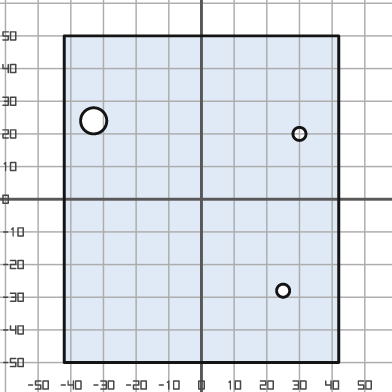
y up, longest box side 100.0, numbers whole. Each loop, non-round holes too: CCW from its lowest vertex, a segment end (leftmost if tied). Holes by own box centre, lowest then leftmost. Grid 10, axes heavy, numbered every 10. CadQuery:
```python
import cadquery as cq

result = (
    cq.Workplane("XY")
    .moveTo(-42.0, -50.0)
    .lineTo(42.0, -50.0)
    .lineTo(42.0, 50.0)
    .lineTo(-42.0, 50.0)
    .close()
    .moveTo(25.0, -28.0)
    .circle(2.0)
    .moveTo(30.0, 20.0)
    .circle(2.0)
    .moveTo(-33.0, 24.0)
    .circle(4.0)
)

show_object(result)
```